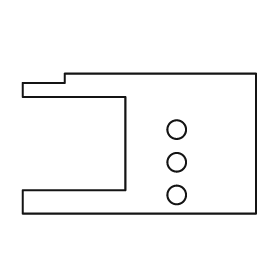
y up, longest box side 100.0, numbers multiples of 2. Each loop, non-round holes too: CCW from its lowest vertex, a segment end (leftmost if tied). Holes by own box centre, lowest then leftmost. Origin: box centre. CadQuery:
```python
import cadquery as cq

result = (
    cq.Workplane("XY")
    .moveTo(-50.0, -30.0)
    .lineTo(50.0, -30.0)
    .lineTo(50.0, 30.0)
    .lineTo(-32.0, 30.0)
    .lineTo(-32.0, 26.0)
    .lineTo(-50.0, 26.0)
    .lineTo(-50.0, 20.0)
    .lineTo(-6.0, 20.0)
    .lineTo(-6.0, -20.0)
    .lineTo(-50.0, -20.0)
    .close()
    .moveTo(16.0, -22.0)
    .circle(4.0)
    .moveTo(16.0, -8.0)
    .circle(4.0)
    .moveTo(16.0, 6.0)
    .circle(4.0)
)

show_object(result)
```